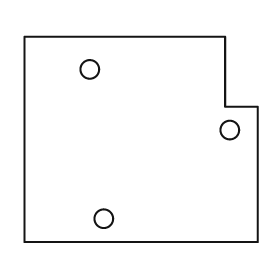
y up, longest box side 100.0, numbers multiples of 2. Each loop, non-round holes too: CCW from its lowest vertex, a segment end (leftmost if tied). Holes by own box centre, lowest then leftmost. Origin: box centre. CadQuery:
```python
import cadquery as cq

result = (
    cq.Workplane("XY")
    .moveTo(-50.0, -44.0)
    .lineTo(50.0, -44.0)
    .lineTo(50.0, 14.0)
    .lineTo(36.0, 14.0)
    .lineTo(36.0, 44.0)
    .lineTo(-50.0, 44.0)
    .close()
    .moveTo(-16.0, -34.0)
    .circle(4.0)
    .moveTo(38.0, 4.0)
    .circle(4.0)
    .moveTo(-22.0, 30.0)
    .circle(4.0)
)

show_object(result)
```